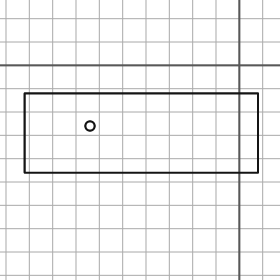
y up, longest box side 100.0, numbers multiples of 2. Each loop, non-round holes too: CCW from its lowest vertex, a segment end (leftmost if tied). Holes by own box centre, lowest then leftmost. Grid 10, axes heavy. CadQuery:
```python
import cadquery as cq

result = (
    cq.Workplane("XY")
    .moveTo(-92.0, -46.0)
    .lineTo(8.0, -46.0)
    .lineTo(8.0, -12.0)
    .lineTo(-92.0, -12.0)
    .close()
    .moveTo(-64.0, -26.0)
    .circle(2.0)
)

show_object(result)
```